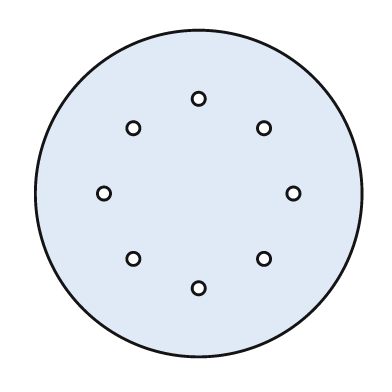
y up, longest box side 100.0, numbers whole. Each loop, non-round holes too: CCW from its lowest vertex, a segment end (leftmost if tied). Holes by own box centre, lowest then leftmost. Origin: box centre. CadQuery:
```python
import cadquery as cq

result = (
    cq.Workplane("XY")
    .moveTo(0.0, 0.0)
    .circle(50.0)
    .moveTo(0.0, -29.0)
    .circle(2.0)
    .moveTo(-20.0, -20.0)
    .circle(2.0)
    .moveTo(20.0, -20.0)
    .circle(2.0)
    .moveTo(-29.0, 0.0)
    .circle(2.0)
    .moveTo(29.0, 0.0)
    .circle(2.0)
    .moveTo(-20.0, 20.0)
    .circle(2.0)
    .moveTo(20.0, 20.0)
    .circle(2.0)
    .moveTo(0.0, 29.0)
    .circle(2.0)
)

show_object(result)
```